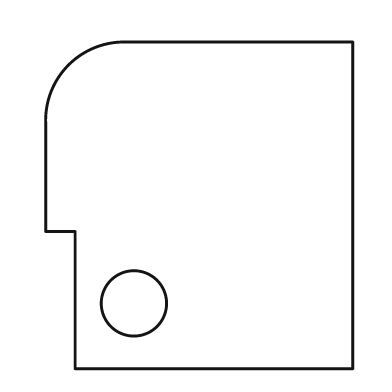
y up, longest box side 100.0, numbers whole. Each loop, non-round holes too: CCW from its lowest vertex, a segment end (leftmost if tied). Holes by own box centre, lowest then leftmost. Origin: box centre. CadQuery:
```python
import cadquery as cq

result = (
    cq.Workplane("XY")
    .moveTo(-38.0, -50.0)
    .lineTo(47.0, -50.0)
    .lineTo(47.0, 50.0)
    .lineTo(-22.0, 50.0)
    .threePointArc((-40.0, 43.0), (-47.0, 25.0))
    .lineTo(-47.0, -8.0)
    .lineTo(-38.0, -8.0)
    .close()
    .moveTo(-20.0, -30.0)
    .circle(10.0)
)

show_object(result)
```